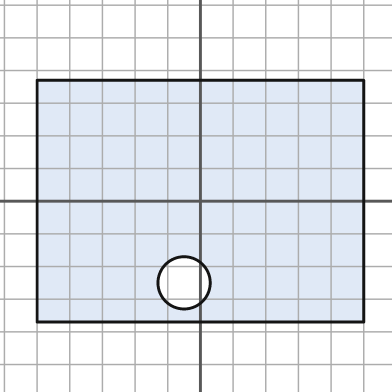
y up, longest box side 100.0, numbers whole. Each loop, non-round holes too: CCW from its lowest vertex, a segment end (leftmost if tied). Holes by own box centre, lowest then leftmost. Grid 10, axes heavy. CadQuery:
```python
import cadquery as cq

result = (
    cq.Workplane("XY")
    .moveTo(-50.0, -37.0)
    .lineTo(50.0, -37.0)
    .lineTo(50.0, 37.0)
    .lineTo(-50.0, 37.0)
    .close()
    .moveTo(-5.0, -25.0)
    .circle(8.0)
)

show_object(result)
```